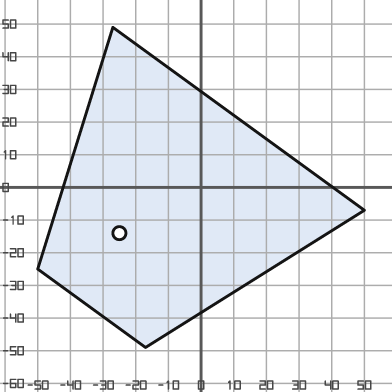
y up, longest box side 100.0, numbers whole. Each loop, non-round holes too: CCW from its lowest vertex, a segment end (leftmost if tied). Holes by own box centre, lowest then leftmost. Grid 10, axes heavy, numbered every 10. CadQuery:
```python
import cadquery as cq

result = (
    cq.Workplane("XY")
    .moveTo(-17.0, -49.0)
    .lineTo(50.0, -7.0)
    .lineTo(-27.0, 49.0)
    .lineTo(-50.0, -25.0)
    .close()
    .moveTo(-25.0, -14.0)
    .circle(2.0)
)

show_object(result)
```